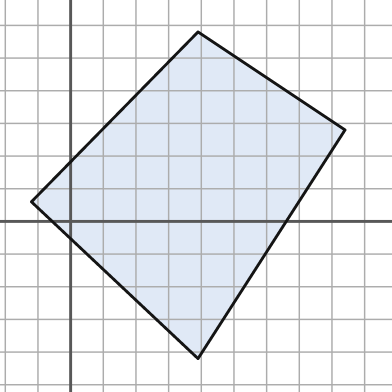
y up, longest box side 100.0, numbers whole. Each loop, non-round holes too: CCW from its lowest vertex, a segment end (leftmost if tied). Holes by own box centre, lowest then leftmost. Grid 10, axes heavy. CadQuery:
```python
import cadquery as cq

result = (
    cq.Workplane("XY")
    .moveTo(39.0, -42.0)
    .lineTo(84.0, 28.0)
    .lineTo(39.0, 58.0)
    .lineTo(-12.0, 6.0)
    .close()
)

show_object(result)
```